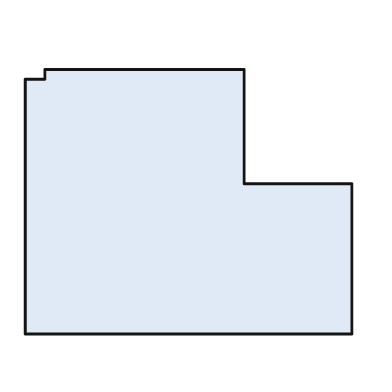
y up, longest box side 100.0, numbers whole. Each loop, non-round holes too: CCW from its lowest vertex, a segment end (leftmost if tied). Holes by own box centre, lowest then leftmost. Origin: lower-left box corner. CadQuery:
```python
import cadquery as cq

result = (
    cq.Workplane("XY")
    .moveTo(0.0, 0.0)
    .lineTo(100.0, 0.0)
    .lineTo(100.0, 46.0)
    .lineTo(67.0, 46.0)
    .lineTo(67.0, 81.0)
    .lineTo(6.0, 81.0)
    .lineTo(6.0, 78.0)
    .lineTo(0.0, 78.0)
    .close()
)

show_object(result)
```